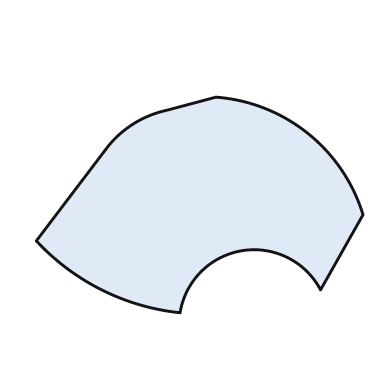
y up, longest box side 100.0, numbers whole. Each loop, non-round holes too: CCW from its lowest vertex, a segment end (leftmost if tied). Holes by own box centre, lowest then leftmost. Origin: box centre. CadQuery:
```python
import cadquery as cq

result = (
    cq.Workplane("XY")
    .moveTo(-6.0, -33.0)
    .threePointArc((13.0, -14.0), (37.0, -26.0))
    .lineTo(50.0, -3.0)
    .threePointArc((33.0, 22.0), (5.0, 33.0))
    .lineTo(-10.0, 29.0)
    .threePointArc((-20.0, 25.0), (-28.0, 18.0))
    .lineTo(-50.0, -11.0)
    .threePointArc((-30.0, -26.0), (-6.0, -33.0))
    .close()
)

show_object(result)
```